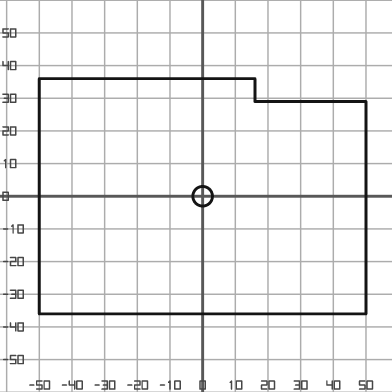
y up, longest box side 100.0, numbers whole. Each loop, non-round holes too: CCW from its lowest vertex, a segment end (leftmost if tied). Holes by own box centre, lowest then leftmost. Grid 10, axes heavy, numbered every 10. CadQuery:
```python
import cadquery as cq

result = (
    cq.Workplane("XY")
    .moveTo(-50.0, -36.0)
    .lineTo(50.0, -36.0)
    .lineTo(50.0, 29.0)
    .lineTo(16.0, 29.0)
    .lineTo(16.0, 36.0)
    .lineTo(-50.0, 36.0)
    .close()
    .moveTo(0.0, 0.0)
    .circle(3.0)
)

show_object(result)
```